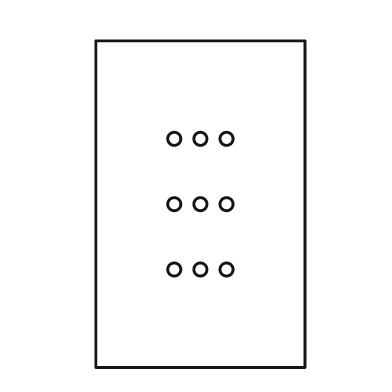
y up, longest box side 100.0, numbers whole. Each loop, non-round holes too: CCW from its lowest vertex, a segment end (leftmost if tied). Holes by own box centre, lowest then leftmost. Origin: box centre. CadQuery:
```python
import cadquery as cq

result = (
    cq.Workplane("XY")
    .moveTo(-32.0, -50.0)
    .lineTo(32.0, -50.0)
    .lineTo(32.0, 50.0)
    .lineTo(-32.0, 50.0)
    .close()
    .moveTo(-8.0, -20.0)
    .circle(2.0)
    .moveTo(0.0, -20.0)
    .circle(2.0)
    .moveTo(8.0, -20.0)
    .circle(2.0)
    .moveTo(-8.0, 0.0)
    .circle(2.0)
    .moveTo(0.0, 0.0)
    .circle(2.0)
    .moveTo(8.0, 0.0)
    .circle(2.0)
    .moveTo(-8.0, 20.0)
    .circle(2.0)
    .moveTo(0.0, 20.0)
    .circle(2.0)
    .moveTo(8.0, 20.0)
    .circle(2.0)
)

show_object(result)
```